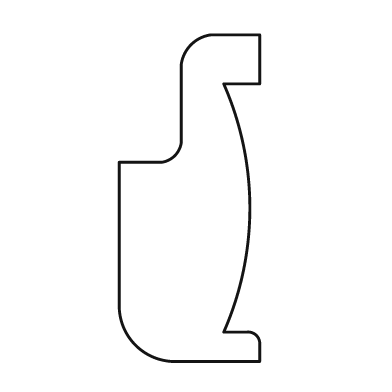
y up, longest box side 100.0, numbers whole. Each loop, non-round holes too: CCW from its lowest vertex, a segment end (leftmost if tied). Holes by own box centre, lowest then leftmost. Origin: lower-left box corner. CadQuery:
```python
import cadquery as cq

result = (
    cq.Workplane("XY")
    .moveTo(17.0, 0.0)
    .lineTo(43.0, 0.0)
    .lineTo(43.0, 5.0)
    .threePointArc((42.0, 8.0), (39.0, 9.0))
    .lineTo(32.0, 9.0)
    .threePointArc((40.0, 47.0), (32.0, 85.0))
    .lineTo(43.0, 85.0)
    .lineTo(43.0, 100.0)
    .lineTo(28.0, 100.0)
    .threePointArc((22.0, 97.0), (19.0, 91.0))
    .lineTo(19.0, 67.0)
    .threePointArc((17.0, 63.0), (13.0, 61.0))
    .lineTo(0.0, 61.0)
    .lineTo(0.0, 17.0)
    .threePointArc((5.0, 5.0), (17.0, 0.0))
    .close()
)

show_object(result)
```